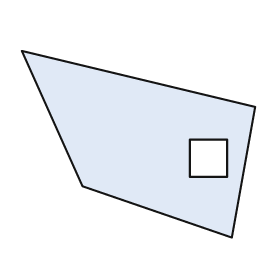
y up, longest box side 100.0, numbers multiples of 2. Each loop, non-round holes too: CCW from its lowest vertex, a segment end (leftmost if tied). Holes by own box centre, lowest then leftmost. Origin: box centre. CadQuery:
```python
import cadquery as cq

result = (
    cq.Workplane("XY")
    .moveTo(40.0, -40.0)
    .lineTo(50.0, 16.0)
    .lineTo(-50.0, 40.0)
    .lineTo(-24.0, -18.0)
    .close()
    .moveTo(22.0, -14.0)
    .lineTo(38.0, -14.0)
    .lineTo(38.0, 2.0)
    .lineTo(22.0, 2.0)
    .close()
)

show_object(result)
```